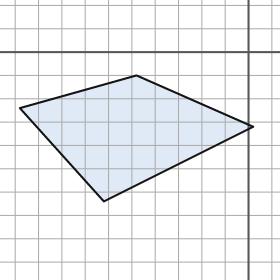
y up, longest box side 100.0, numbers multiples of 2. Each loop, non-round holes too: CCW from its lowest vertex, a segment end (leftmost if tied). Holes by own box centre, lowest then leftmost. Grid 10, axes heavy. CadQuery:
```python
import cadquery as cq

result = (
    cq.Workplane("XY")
    .moveTo(-62.0, -64.0)
    .lineTo(2.0, -32.0)
    .lineTo(-48.0, -10.0)
    .lineTo(-98.0, -24.0)
    .close()
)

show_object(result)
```